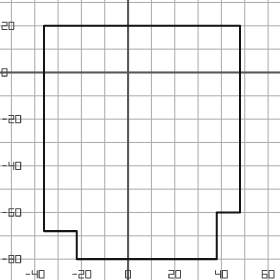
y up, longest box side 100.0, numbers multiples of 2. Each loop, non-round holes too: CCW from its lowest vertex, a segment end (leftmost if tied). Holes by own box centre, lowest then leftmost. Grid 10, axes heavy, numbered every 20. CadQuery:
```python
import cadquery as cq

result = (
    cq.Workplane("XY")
    .moveTo(-22.0, -80.0)
    .lineTo(38.0, -80.0)
    .lineTo(38.0, -60.0)
    .lineTo(48.0, -60.0)
    .lineTo(48.0, 20.0)
    .lineTo(-36.0, 20.0)
    .lineTo(-36.0, -68.0)
    .lineTo(-22.0, -68.0)
    .close()
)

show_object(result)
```